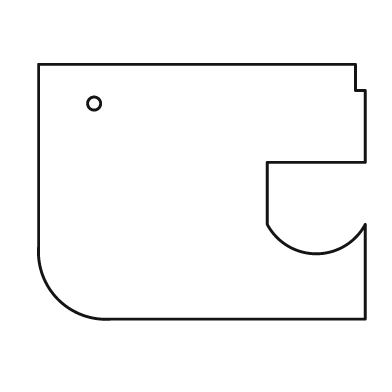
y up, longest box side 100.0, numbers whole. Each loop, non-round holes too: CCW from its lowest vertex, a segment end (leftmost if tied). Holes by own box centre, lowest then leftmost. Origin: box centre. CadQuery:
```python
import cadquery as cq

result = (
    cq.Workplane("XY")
    .moveTo(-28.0, -39.0)
    .lineTo(50.0, -39.0)
    .lineTo(50.0, -10.0)
    .threePointArc((35.0, -19.0), (20.0, -10.0))
    .lineTo(20.0, 9.0)
    .lineTo(50.0, 9.0)
    .lineTo(50.0, 31.0)
    .lineTo(47.0, 31.0)
    .lineTo(47.0, 39.0)
    .lineTo(-50.0, 39.0)
    .lineTo(-50.0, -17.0)
    .threePointArc((-44.0, -33.0), (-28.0, -39.0))
    .close()
    .moveTo(-33.0, 27.0)
    .circle(2.0)
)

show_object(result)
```